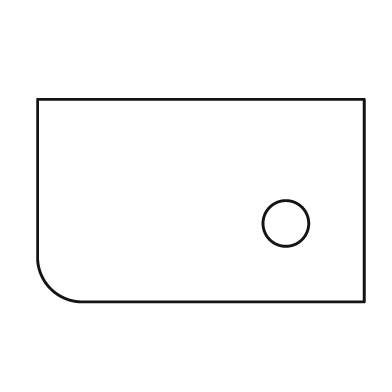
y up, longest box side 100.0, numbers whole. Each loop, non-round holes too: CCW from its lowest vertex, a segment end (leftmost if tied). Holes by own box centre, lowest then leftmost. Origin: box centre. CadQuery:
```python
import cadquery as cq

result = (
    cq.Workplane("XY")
    .moveTo(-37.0, -31.0)
    .lineTo(50.0, -31.0)
    .lineTo(50.0, 31.0)
    .lineTo(-50.0, 31.0)
    .lineTo(-50.0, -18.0)
    .threePointArc((-46.0, -27.0), (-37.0, -31.0))
    .close()
    .moveTo(26.0, -7.0)
    .circle(7.0)
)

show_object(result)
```